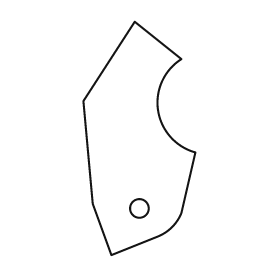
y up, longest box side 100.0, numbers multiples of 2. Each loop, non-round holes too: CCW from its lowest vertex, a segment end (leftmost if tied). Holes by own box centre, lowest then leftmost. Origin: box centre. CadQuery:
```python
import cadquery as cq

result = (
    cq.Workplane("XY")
    .moveTo(-12.0, -50.0)
    .lineTo(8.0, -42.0)
    .threePointArc((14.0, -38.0), (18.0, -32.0))
    .lineTo(24.0, -6.0)
    .threePointArc((8.0, 12.0), (18.0, 34.0))
    .lineTo(-2.0, 50.0)
    .lineTo(-24.0, 16.0)
    .lineTo(-20.0, -28.0)
    .close()
    .moveTo(0.0, -30.0)
    .circle(4.0)
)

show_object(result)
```